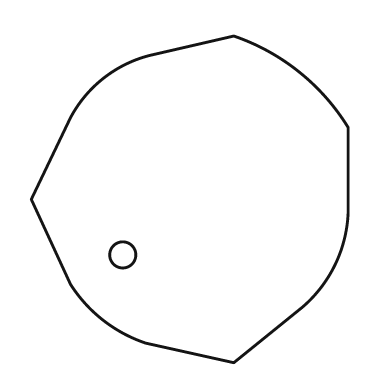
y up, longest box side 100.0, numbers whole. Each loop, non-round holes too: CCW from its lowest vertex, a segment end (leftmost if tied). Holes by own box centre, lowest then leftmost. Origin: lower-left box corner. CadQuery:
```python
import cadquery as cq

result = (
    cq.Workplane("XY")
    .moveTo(62.0, 0.0)
    .lineTo(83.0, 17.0)
    .threePointArc((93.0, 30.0), (97.0, 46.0))
    .lineTo(97.0, 72.0)
    .threePointArc((82.0, 89.0), (62.0, 100.0))
    .lineTo(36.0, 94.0)
    .threePointArc((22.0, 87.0), (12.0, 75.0))
    .lineTo(0.0, 50.0)
    .lineTo(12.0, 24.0)
    .threePointArc((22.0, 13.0), (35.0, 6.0))
    .close()
    .moveTo(28.0, 33.0)
    .circle(4.0)
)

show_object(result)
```